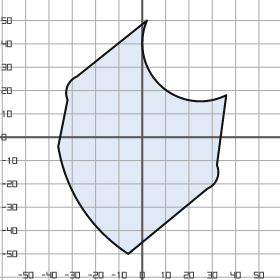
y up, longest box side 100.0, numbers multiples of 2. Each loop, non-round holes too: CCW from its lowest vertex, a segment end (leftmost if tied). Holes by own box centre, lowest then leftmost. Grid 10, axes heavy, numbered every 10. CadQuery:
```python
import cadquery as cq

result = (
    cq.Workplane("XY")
    .moveTo(-6.0, -50.0)
    .lineTo(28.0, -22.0)
    .threePointArc((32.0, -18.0), (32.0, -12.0))
    .lineTo(36.0, 18.0)
    .threePointArc((8.0, 22.0), (2.0, 50.0))
    .lineTo(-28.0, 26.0)
    .threePointArc((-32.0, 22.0), (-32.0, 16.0))
    .lineTo(-36.0, -4.0)
    .threePointArc((-26.0, -30.0), (-6.0, -50.0))
    .close()
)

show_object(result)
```